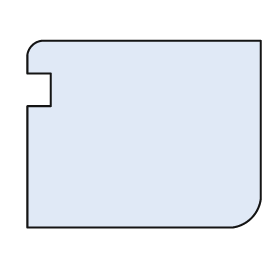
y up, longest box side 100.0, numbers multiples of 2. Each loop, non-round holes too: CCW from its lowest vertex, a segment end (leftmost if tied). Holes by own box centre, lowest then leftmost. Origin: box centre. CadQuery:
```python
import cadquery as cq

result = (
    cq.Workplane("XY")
    .moveTo(-50.0, -40.0)
    .lineTo(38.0, -40.0)
    .threePointArc((46.0, -36.0), (50.0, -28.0))
    .lineTo(50.0, 40.0)
    .lineTo(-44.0, 40.0)
    .threePointArc((-48.0, 38.0), (-50.0, 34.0))
    .lineTo(-50.0, 26.0)
    .lineTo(-40.0, 26.0)
    .lineTo(-40.0, 12.0)
    .lineTo(-50.0, 12.0)
    .close()
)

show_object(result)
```